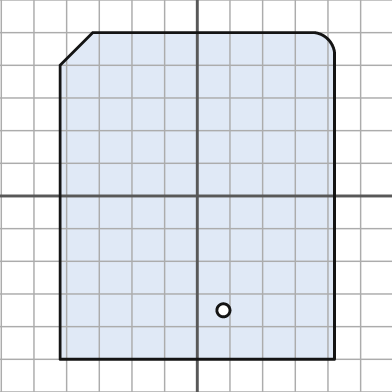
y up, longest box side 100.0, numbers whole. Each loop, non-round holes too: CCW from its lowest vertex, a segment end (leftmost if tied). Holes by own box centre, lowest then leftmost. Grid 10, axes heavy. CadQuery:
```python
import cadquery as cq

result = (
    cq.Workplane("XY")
    .moveTo(-42.0, -50.0)
    .lineTo(42.0, -50.0)
    .lineTo(42.0, 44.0)
    .threePointArc((40.0, 48.0), (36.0, 50.0))
    .lineTo(-32.0, 50.0)
    .lineTo(-42.0, 40.0)
    .close()
    .moveTo(8.0, -35.0)
    .circle(2.0)
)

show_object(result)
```